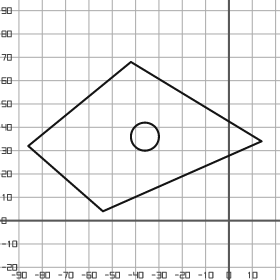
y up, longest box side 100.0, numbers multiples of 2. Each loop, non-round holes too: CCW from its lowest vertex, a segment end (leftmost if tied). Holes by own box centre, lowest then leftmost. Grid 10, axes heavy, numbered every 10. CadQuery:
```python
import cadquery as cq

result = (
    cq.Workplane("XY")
    .moveTo(-54.0, 4.0)
    .lineTo(14.0, 34.0)
    .lineTo(-42.0, 68.0)
    .lineTo(-86.0, 32.0)
    .close()
    .moveTo(-36.0, 36.0)
    .circle(6.0)
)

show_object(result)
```